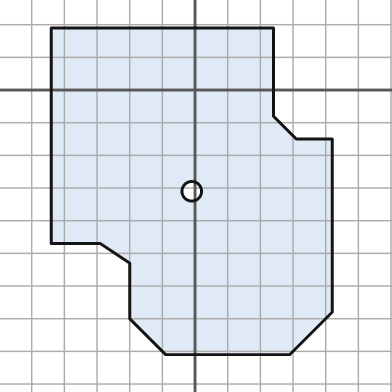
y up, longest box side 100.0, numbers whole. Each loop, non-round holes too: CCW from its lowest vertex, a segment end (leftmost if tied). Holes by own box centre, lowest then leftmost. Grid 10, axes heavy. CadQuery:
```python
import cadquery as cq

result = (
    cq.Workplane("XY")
    .moveTo(-9.0, -81.0)
    .lineTo(29.0, -81.0)
    .lineTo(42.0, -68.0)
    .lineTo(42.0, -15.0)
    .lineTo(31.0, -15.0)
    .lineTo(24.0, -8.0)
    .lineTo(24.0, 19.0)
    .lineTo(-44.0, 19.0)
    .lineTo(-44.0, -47.0)
    .lineTo(-29.0, -47.0)
    .lineTo(-20.0, -53.0)
    .lineTo(-20.0, -70.0)
    .close()
    .moveTo(-1.0, -31.0)
    .circle(3.0)
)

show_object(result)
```